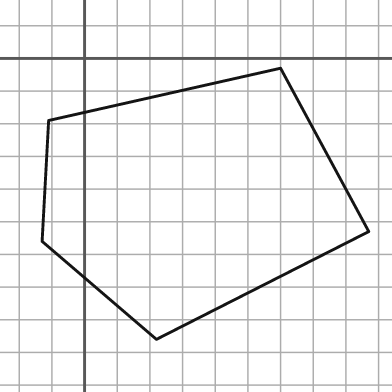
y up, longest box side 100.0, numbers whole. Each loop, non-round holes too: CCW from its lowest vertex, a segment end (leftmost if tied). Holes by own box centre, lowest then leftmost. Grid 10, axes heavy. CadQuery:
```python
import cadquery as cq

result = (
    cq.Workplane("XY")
    .moveTo(22.0, -86.0)
    .lineTo(87.0, -53.0)
    .lineTo(60.0, -3.0)
    .lineTo(-11.0, -19.0)
    .lineTo(-13.0, -56.0)
    .close()
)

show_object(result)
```